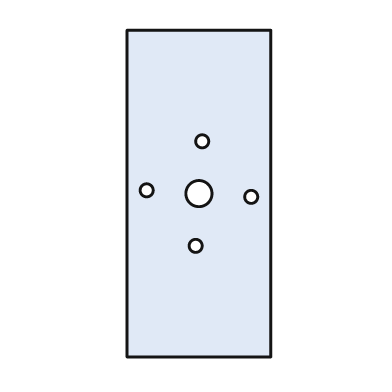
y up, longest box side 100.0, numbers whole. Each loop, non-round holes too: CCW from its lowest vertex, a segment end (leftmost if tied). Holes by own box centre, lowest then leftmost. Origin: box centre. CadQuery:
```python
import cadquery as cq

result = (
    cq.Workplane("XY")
    .moveTo(-22.0, -50.0)
    .lineTo(22.0, -50.0)
    .lineTo(22.0, 50.0)
    .lineTo(-22.0, 50.0)
    .close()
    .moveTo(-1.0, -16.0)
    .circle(2.0)
    .moveTo(16.0, -1.0)
    .circle(2.0)
    .moveTo(0.0, 0.0)
    .circle(4.0)
    .moveTo(-16.0, 1.0)
    .circle(2.0)
    .moveTo(1.0, 16.0)
    .circle(2.0)
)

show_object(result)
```